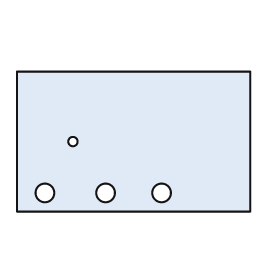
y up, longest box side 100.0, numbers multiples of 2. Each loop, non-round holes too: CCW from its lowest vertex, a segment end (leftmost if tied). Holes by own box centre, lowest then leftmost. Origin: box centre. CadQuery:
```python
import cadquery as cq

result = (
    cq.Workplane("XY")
    .moveTo(-50.0, -30.0)
    .lineTo(50.0, -30.0)
    .lineTo(50.0, 30.0)
    .lineTo(-50.0, 30.0)
    .close()
    .moveTo(-38.0, -22.0)
    .circle(4.0)
    .moveTo(-12.0, -22.0)
    .circle(4.0)
    .moveTo(12.0, -22.0)
    .circle(4.0)
    .moveTo(-26.0, 0.0)
    .circle(2.0)
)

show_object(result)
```